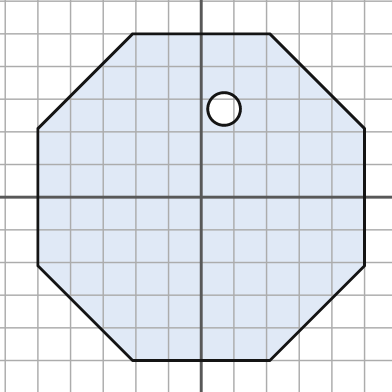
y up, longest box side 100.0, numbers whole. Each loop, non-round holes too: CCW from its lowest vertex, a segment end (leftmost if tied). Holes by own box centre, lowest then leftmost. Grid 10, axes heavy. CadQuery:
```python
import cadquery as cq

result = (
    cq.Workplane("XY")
    .moveTo(-21.0, -50.0)
    .lineTo(21.0, -50.0)
    .lineTo(50.0, -21.0)
    .lineTo(50.0, 21.0)
    .lineTo(21.0, 50.0)
    .lineTo(-21.0, 50.0)
    .lineTo(-50.0, 21.0)
    .lineTo(-50.0, -21.0)
    .close()
    .moveTo(7.0, 27.0)
    .circle(5.0)
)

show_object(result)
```